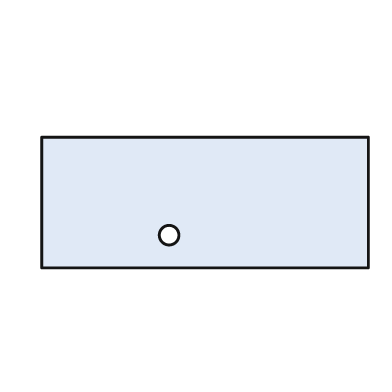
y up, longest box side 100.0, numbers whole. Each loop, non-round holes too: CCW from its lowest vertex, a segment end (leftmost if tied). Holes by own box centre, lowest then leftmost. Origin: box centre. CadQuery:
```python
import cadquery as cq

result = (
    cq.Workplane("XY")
    .moveTo(-50.0, -20.0)
    .lineTo(50.0, -20.0)
    .lineTo(50.0, 20.0)
    .lineTo(-50.0, 20.0)
    .close()
    .moveTo(-11.0, -10.0)
    .circle(3.0)
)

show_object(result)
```